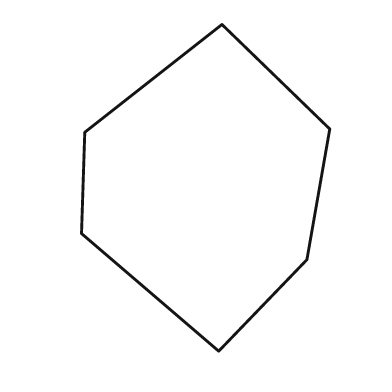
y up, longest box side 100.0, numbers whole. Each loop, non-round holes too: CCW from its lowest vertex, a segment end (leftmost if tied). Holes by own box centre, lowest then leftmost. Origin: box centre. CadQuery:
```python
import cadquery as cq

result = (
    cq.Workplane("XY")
    .moveTo(4.0, -50.0)
    .lineTo(31.0, -22.0)
    .lineTo(38.0, 18.0)
    .lineTo(5.0, 50.0)
    .lineTo(-37.0, 17.0)
    .lineTo(-38.0, -14.0)
    .close()
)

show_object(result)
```